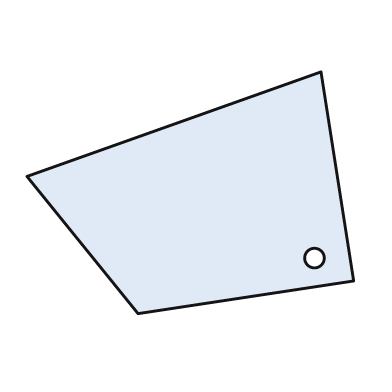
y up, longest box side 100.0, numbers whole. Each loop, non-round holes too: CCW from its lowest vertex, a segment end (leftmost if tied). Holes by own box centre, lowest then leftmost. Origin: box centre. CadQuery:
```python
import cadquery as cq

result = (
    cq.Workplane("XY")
    .moveTo(-16.0, -37.0)
    .lineTo(50.0, -27.0)
    .lineTo(40.0, 37.0)
    .lineTo(-50.0, 5.0)
    .close()
    .moveTo(38.0, -20.0)
    .circle(3.0)
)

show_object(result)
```